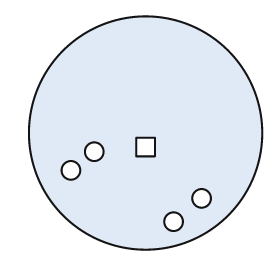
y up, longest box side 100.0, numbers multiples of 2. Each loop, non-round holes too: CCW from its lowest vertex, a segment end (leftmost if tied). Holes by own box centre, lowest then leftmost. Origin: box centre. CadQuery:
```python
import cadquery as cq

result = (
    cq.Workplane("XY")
    .moveTo(0.0, 0.0)
    .circle(50.0)
    .moveTo(12.0, -38.0)
    .circle(4.0)
    .moveTo(24.0, -28.0)
    .circle(4.0)
    .moveTo(-32.0, -16.0)
    .circle(4.0)
    .moveTo(-22.0, -8.0)
    .circle(4.0)
    .moveTo(-4.0, -10.0)
    .lineTo(4.0, -10.0)
    .lineTo(4.0, -2.0)
    .lineTo(-4.0, -2.0)
    .close()
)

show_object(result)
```